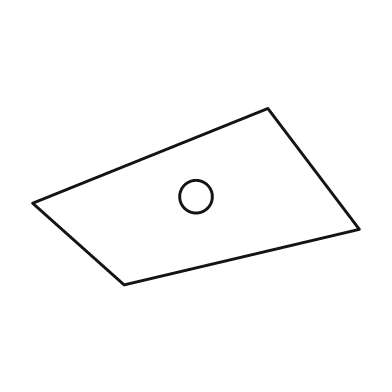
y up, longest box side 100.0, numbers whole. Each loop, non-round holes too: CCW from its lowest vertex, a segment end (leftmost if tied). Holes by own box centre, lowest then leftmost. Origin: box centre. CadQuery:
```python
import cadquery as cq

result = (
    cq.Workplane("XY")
    .moveTo(-22.0, -27.0)
    .lineTo(50.0, -10.0)
    .lineTo(22.0, 27.0)
    .lineTo(-50.0, -2.0)
    .close()
    .moveTo(0.0, 0.0)
    .circle(5.0)
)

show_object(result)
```